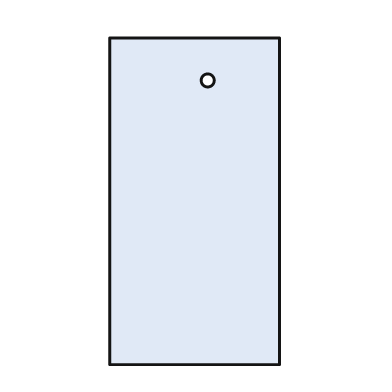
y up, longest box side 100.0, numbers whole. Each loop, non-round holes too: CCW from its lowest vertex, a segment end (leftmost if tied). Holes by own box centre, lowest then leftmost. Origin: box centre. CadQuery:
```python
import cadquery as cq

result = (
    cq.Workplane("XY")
    .moveTo(-26.0, -50.0)
    .lineTo(26.0, -50.0)
    .lineTo(26.0, 50.0)
    .lineTo(-26.0, 50.0)
    .close()
    .moveTo(4.0, 37.0)
    .circle(2.0)
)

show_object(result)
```